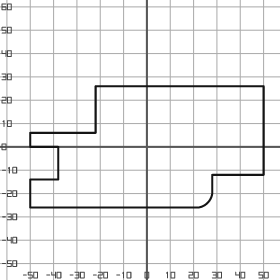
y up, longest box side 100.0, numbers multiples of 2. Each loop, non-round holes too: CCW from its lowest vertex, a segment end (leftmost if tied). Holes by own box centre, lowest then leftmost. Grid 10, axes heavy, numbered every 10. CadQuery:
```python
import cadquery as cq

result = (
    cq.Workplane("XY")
    .moveTo(-50.0, -26.0)
    .lineTo(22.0, -26.0)
    .threePointArc((26.0, -24.0), (28.0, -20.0))
    .lineTo(28.0, -12.0)
    .lineTo(50.0, -12.0)
    .lineTo(50.0, 26.0)
    .lineTo(-22.0, 26.0)
    .lineTo(-22.0, 6.0)
    .lineTo(-50.0, 6.0)
    .lineTo(-50.0, 0.0)
    .lineTo(-38.0, 0.0)
    .lineTo(-38.0, -14.0)
    .lineTo(-50.0, -14.0)
    .close()
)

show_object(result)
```